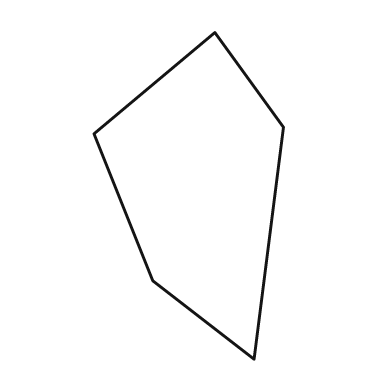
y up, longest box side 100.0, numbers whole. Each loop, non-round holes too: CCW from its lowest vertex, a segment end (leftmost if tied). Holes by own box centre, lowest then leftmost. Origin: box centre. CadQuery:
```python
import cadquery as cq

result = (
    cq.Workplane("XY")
    .moveTo(20.0, -50.0)
    .lineTo(29.0, 21.0)
    .lineTo(8.0, 50.0)
    .lineTo(-29.0, 19.0)
    .lineTo(-11.0, -26.0)
    .close()
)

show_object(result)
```